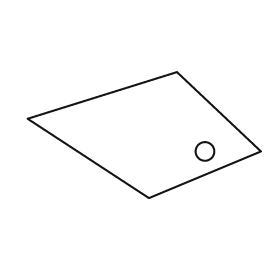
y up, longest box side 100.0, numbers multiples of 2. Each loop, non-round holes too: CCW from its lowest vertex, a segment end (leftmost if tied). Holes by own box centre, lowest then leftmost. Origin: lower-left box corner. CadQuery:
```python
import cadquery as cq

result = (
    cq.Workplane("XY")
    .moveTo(52.0, 0.0)
    .lineTo(100.0, 20.0)
    .lineTo(64.0, 54.0)
    .lineTo(0.0, 34.0)
    .close()
    .moveTo(76.0, 20.0)
    .circle(4.0)
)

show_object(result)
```